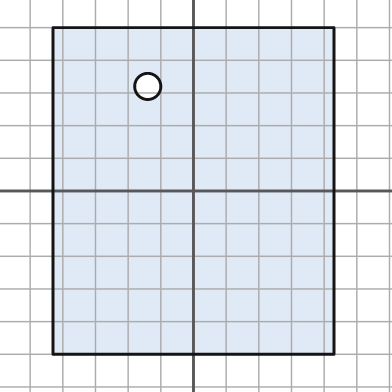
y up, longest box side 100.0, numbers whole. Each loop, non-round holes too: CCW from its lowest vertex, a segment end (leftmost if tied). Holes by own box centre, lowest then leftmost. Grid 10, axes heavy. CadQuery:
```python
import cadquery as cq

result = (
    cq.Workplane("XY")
    .moveTo(-43.0, -50.0)
    .lineTo(43.0, -50.0)
    .lineTo(43.0, 50.0)
    .lineTo(-43.0, 50.0)
    .close()
    .moveTo(-14.0, 32.0)
    .circle(4.0)
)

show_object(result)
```